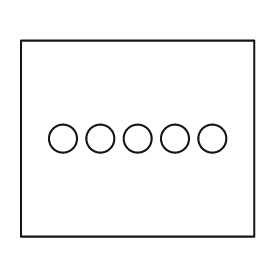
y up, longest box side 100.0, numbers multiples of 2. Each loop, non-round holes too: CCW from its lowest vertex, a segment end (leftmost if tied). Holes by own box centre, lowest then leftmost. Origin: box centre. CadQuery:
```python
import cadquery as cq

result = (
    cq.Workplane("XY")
    .moveTo(-50.0, -42.0)
    .lineTo(50.0, -42.0)
    .lineTo(50.0, 42.0)
    .lineTo(-50.0, 42.0)
    .close()
    .moveTo(-32.0, 0.0)
    .circle(6.0)
    .moveTo(-16.0, 0.0)
    .circle(6.0)
    .moveTo(0.0, 0.0)
    .circle(6.0)
    .moveTo(16.0, 0.0)
    .circle(6.0)
    .moveTo(32.0, 0.0)
    .circle(6.0)
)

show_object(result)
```